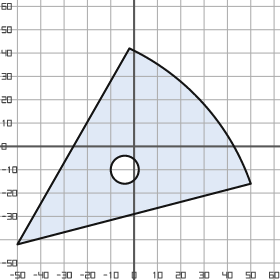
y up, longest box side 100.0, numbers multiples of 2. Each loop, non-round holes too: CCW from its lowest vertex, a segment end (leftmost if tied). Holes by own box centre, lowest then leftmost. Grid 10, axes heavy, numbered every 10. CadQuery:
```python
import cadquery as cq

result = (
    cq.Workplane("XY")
    .moveTo(-50.0, -42.0)
    .lineTo(50.0, -16.0)
    .threePointArc((30.0, 18.0), (-2.0, 42.0))
    .close()
    .moveTo(-4.0, -10.0)
    .circle(6.0)
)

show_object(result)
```